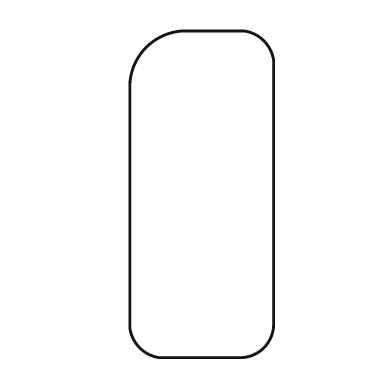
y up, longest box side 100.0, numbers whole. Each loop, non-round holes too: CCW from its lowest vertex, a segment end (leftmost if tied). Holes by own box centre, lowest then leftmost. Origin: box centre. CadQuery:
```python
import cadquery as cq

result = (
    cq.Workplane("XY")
    .moveTo(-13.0, -50.0)
    .lineTo(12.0, -50.0)
    .threePointArc((19.0, -47.0), (22.0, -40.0))
    .lineTo(22.0, 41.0)
    .threePointArc((19.0, 47.0), (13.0, 50.0))
    .lineTo(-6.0, 50.0)
    .threePointArc((-17.0, 45.0), (-22.0, 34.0))
    .lineTo(-22.0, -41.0)
    .threePointArc((-19.0, -47.0), (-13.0, -50.0))
    .close()
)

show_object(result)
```